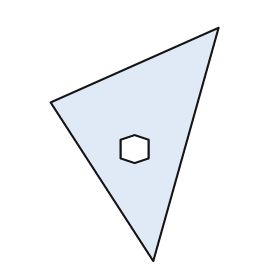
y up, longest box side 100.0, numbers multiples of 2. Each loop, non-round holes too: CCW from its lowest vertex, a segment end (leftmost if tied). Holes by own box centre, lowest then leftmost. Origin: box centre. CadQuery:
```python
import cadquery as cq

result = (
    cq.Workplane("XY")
    .moveTo(8.0, -50.0)
    .lineTo(36.0, 50.0)
    .lineTo(-36.0, 18.0)
    .close()
    .moveTo(0.0, -8.0)
    .lineTo(6.0, -6.0)
    .lineTo(6.0, 2.0)
    .lineTo(0.0, 4.0)
    .lineTo(-6.0, 2.0)
    .lineTo(-6.0, -6.0)
    .close()
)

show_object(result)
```